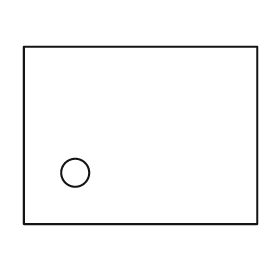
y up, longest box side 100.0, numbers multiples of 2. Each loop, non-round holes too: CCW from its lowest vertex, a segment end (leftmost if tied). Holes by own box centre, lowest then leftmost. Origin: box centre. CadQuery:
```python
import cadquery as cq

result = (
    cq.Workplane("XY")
    .moveTo(-50.0, -38.0)
    .lineTo(50.0, -38.0)
    .lineTo(50.0, 38.0)
    .lineTo(-50.0, 38.0)
    .close()
    .moveTo(-28.0, -16.0)
    .circle(6.0)
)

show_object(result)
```